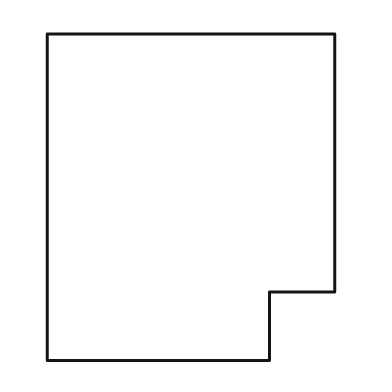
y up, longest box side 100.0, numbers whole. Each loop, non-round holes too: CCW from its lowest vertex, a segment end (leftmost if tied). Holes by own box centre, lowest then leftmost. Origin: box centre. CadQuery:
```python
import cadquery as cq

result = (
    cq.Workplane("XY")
    .moveTo(-44.0, -50.0)
    .lineTo(24.0, -50.0)
    .lineTo(24.0, -29.0)
    .lineTo(44.0, -29.0)
    .lineTo(44.0, 50.0)
    .lineTo(-44.0, 50.0)
    .close()
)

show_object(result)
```